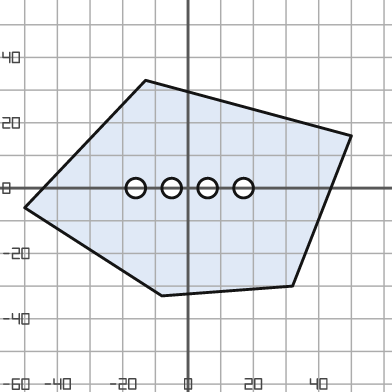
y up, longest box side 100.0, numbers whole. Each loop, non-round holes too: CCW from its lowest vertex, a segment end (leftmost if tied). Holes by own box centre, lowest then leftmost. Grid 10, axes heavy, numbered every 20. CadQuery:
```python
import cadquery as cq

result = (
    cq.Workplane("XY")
    .moveTo(-8.0, -33.0)
    .lineTo(32.0, -30.0)
    .lineTo(50.0, 16.0)
    .lineTo(-13.0, 33.0)
    .lineTo(-50.0, -6.0)
    .close()
    .moveTo(-16.0, 0.0)
    .circle(3.0)
    .moveTo(-5.0, 0.0)
    .circle(3.0)
    .moveTo(6.0, 0.0)
    .circle(3.0)
    .moveTo(17.0, 0.0)
    .circle(3.0)
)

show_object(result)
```